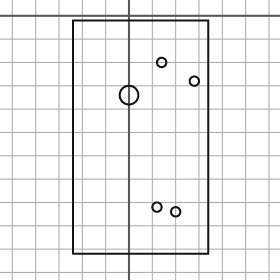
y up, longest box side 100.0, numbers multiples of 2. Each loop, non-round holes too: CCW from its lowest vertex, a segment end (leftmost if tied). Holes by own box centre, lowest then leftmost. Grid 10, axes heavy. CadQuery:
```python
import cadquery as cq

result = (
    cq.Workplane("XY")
    .moveTo(-24.0, -102.0)
    .lineTo(34.0, -102.0)
    .lineTo(34.0, -2.0)
    .lineTo(-24.0, -2.0)
    .close()
    .moveTo(20.0, -84.0)
    .circle(2.0)
    .moveTo(12.0, -82.0)
    .circle(2.0)
    .moveTo(0.0, -34.0)
    .circle(4.0)
    .moveTo(28.0, -28.0)
    .circle(2.0)
    .moveTo(14.0, -20.0)
    .circle(2.0)
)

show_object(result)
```